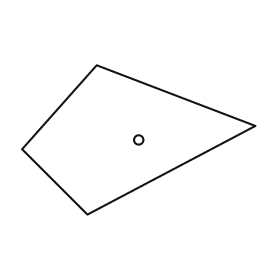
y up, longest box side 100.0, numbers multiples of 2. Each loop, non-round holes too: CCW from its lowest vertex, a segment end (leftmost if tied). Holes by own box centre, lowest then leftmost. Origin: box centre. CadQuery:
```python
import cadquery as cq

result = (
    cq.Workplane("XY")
    .moveTo(-22.0, -32.0)
    .lineTo(50.0, 6.0)
    .lineTo(-18.0, 32.0)
    .lineTo(-50.0, -4.0)
    .close()
    .moveTo(0.0, 0.0)
    .circle(2.0)
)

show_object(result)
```